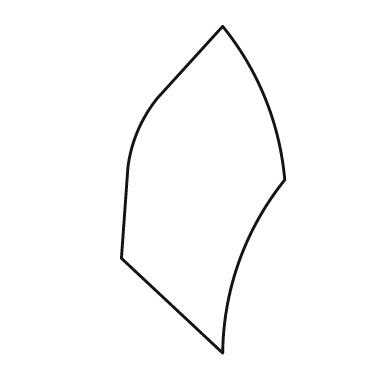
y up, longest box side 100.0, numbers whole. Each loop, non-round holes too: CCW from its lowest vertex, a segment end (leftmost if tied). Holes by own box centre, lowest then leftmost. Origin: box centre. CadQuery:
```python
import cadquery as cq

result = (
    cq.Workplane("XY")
    .moveTo(6.0, -50.0)
    .threePointArc((11.0, -22.0), (25.0, 3.0))
    .threePointArc((19.0, 28.0), (6.0, 50.0))
    .lineTo(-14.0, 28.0)
    .threePointArc((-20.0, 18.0), (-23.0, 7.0))
    .lineTo(-25.0, -21.0)
    .close()
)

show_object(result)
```